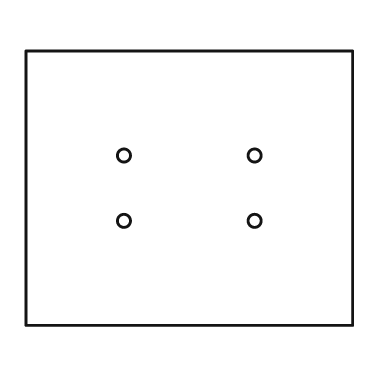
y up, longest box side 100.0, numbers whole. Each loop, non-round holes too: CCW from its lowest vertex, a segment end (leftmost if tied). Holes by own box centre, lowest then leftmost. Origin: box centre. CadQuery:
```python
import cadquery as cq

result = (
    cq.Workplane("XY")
    .moveTo(-50.0, -42.0)
    .lineTo(50.0, -42.0)
    .lineTo(50.0, 42.0)
    .lineTo(-50.0, 42.0)
    .close()
    .moveTo(-20.0, -10.0)
    .circle(2.0)
    .moveTo(20.0, -10.0)
    .circle(2.0)
    .moveTo(-20.0, 10.0)
    .circle(2.0)
    .moveTo(20.0, 10.0)
    .circle(2.0)
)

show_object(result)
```